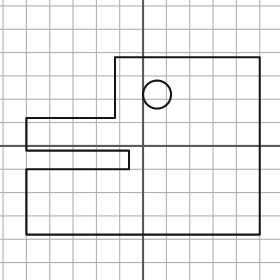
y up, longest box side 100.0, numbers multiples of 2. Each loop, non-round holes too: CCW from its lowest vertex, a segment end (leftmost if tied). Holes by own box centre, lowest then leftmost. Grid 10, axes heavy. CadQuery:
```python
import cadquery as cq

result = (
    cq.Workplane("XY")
    .moveTo(-50.0, -38.0)
    .lineTo(50.0, -38.0)
    .lineTo(50.0, 38.0)
    .lineTo(-12.0, 38.0)
    .lineTo(-12.0, 12.0)
    .lineTo(-50.0, 12.0)
    .lineTo(-50.0, -2.0)
    .lineTo(-6.0, -2.0)
    .lineTo(-6.0, -10.0)
    .lineTo(-50.0, -10.0)
    .close()
    .moveTo(6.0, 22.0)
    .circle(6.0)
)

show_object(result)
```